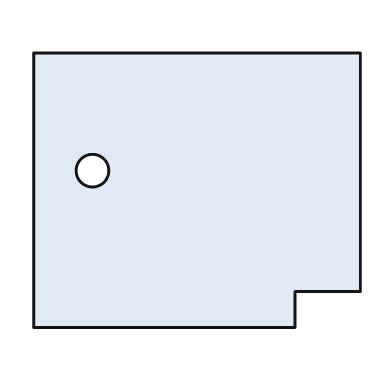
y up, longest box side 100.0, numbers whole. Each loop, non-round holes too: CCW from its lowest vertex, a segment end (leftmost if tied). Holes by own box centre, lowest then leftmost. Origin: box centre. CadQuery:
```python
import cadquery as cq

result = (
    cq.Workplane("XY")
    .moveTo(-50.0, -42.0)
    .lineTo(30.0, -42.0)
    .lineTo(30.0, -31.0)
    .lineTo(50.0, -31.0)
    .lineTo(50.0, 42.0)
    .lineTo(-50.0, 42.0)
    .close()
    .moveTo(-32.0, 6.0)
    .circle(5.0)
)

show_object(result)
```